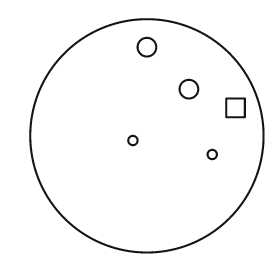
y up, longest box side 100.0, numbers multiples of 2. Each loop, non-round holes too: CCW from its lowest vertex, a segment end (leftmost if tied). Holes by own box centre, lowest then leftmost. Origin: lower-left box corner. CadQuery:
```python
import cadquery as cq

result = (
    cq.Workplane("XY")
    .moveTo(50.0, 50.0)
    .circle(50.0)
    .moveTo(78.0, 42.0)
    .circle(2.0)
    .moveTo(44.0, 48.0)
    .circle(2.0)
    .moveTo(84.0, 58.0)
    .lineTo(92.0, 58.0)
    .lineTo(92.0, 66.0)
    .lineTo(84.0, 66.0)
    .close()
    .moveTo(68.0, 70.0)
    .circle(4.0)
    .moveTo(50.0, 88.0)
    .circle(4.0)
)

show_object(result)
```